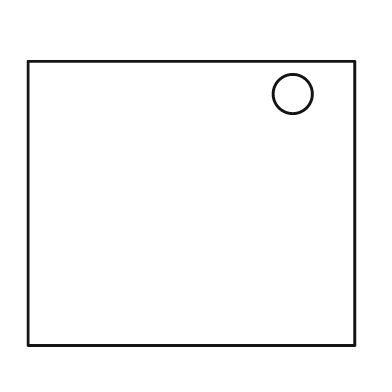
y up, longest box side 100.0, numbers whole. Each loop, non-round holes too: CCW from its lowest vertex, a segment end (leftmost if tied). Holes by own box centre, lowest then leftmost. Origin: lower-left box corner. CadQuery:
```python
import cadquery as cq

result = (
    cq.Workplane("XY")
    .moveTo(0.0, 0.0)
    .lineTo(100.0, 0.0)
    .lineTo(100.0, 87.0)
    .lineTo(0.0, 87.0)
    .close()
    .moveTo(81.0, 77.0)
    .circle(6.0)
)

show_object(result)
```